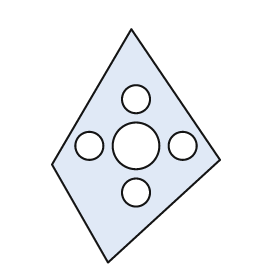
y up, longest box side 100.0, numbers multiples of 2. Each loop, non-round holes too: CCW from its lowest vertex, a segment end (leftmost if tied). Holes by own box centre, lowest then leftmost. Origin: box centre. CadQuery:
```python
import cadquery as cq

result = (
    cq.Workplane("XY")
    .moveTo(-12.0, -50.0)
    .lineTo(36.0, -6.0)
    .lineTo(-2.0, 50.0)
    .lineTo(-36.0, -8.0)
    .close()
    .moveTo(0.0, -20.0)
    .circle(6.0)
    .moveTo(-20.0, 0.0)
    .circle(6.0)
    .moveTo(0.0, 0.0)
    .circle(10.0)
    .moveTo(20.0, 0.0)
    .circle(6.0)
    .moveTo(0.0, 20.0)
    .circle(6.0)
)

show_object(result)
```